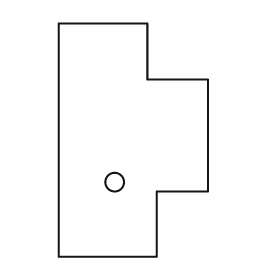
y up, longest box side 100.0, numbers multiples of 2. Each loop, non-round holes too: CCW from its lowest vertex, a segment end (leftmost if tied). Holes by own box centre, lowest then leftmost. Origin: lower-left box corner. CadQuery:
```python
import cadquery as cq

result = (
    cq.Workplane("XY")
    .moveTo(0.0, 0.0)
    .lineTo(42.0, 0.0)
    .lineTo(42.0, 28.0)
    .lineTo(64.0, 28.0)
    .lineTo(64.0, 76.0)
    .lineTo(38.0, 76.0)
    .lineTo(38.0, 100.0)
    .lineTo(0.0, 100.0)
    .close()
    .moveTo(24.0, 32.0)
    .circle(4.0)
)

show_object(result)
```